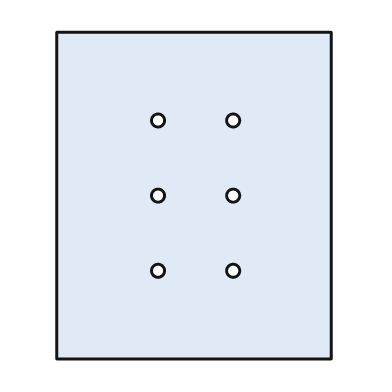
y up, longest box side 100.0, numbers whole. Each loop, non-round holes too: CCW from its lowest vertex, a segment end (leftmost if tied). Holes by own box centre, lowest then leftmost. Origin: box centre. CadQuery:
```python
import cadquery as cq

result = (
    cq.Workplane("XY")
    .moveTo(-42.0, -50.0)
    .lineTo(42.0, -50.0)
    .lineTo(42.0, 50.0)
    .lineTo(-42.0, 50.0)
    .close()
    .moveTo(-11.0, -23.0)
    .circle(2.0)
    .moveTo(12.0, -23.0)
    .circle(2.0)
    .moveTo(-11.0, 0.0)
    .circle(2.0)
    .moveTo(12.0, 0.0)
    .circle(2.0)
    .moveTo(-11.0, 23.0)
    .circle(2.0)
    .moveTo(12.0, 23.0)
    .circle(2.0)
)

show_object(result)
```